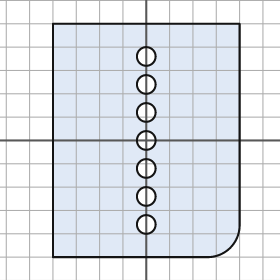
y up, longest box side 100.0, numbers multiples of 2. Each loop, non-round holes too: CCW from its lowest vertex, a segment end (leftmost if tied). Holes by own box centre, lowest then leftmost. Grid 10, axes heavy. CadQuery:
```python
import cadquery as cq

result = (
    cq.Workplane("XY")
    .moveTo(-40.0, -50.0)
    .lineTo(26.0, -50.0)
    .threePointArc((36.0, -46.0), (40.0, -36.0))
    .lineTo(40.0, 50.0)
    .lineTo(-40.0, 50.0)
    .close()
    .moveTo(0.0, -36.0)
    .circle(4.0)
    .moveTo(0.0, -24.0)
    .circle(4.0)
    .moveTo(0.0, -12.0)
    .circle(4.0)
    .moveTo(0.0, 0.0)
    .circle(4.0)
    .moveTo(0.0, 12.0)
    .circle(4.0)
    .moveTo(0.0, 24.0)
    .circle(4.0)
    .moveTo(0.0, 36.0)
    .circle(4.0)
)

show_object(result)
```